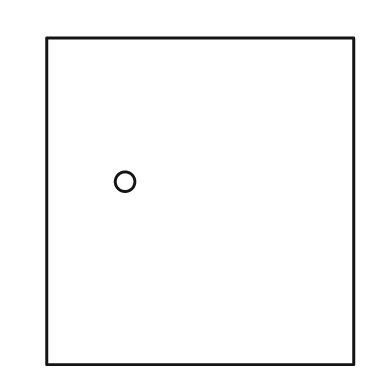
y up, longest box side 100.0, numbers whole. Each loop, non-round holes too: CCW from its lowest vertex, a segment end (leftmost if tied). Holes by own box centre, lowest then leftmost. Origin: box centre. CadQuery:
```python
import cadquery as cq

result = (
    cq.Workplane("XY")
    .moveTo(-47.0, -50.0)
    .lineTo(47.0, -50.0)
    .lineTo(47.0, 50.0)
    .lineTo(-47.0, 50.0)
    .close()
    .moveTo(-23.0, 6.0)
    .circle(3.0)
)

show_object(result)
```